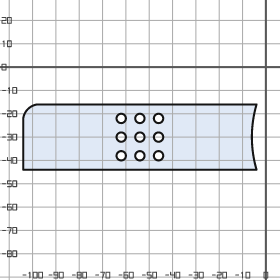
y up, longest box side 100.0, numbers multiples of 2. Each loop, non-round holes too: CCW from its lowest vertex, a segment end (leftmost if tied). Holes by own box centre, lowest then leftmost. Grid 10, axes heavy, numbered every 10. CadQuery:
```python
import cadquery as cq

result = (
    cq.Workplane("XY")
    .moveTo(-104.0, -44.0)
    .lineTo(-4.0, -44.0)
    .threePointArc((-6.0, -30.0), (-4.0, -16.0))
    .lineTo(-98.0, -16.0)
    .threePointArc((-102.0, -18.0), (-104.0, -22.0))
    .close()
    .moveTo(-62.0, -38.0)
    .circle(2.0)
    .moveTo(-54.0, -38.0)
    .circle(2.0)
    .moveTo(-46.0, -38.0)
    .circle(2.0)
    .moveTo(-62.0, -30.0)
    .circle(2.0)
    .moveTo(-54.0, -30.0)
    .circle(2.0)
    .moveTo(-46.0, -30.0)
    .circle(2.0)
    .moveTo(-62.0, -22.0)
    .circle(2.0)
    .moveTo(-54.0, -22.0)
    .circle(2.0)
    .moveTo(-46.0, -22.0)
    .circle(2.0)
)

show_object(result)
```